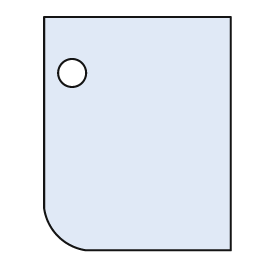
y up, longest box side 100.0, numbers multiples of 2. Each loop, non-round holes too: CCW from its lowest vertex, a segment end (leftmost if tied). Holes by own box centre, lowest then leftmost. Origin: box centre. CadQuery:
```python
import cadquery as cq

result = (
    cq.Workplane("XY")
    .moveTo(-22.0, -50.0)
    .lineTo(40.0, -50.0)
    .lineTo(40.0, 50.0)
    .lineTo(-40.0, 50.0)
    .lineTo(-40.0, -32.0)
    .threePointArc((-34.0, -44.0), (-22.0, -50.0))
    .close()
    .moveTo(-28.0, 26.0)
    .circle(6.0)
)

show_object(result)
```